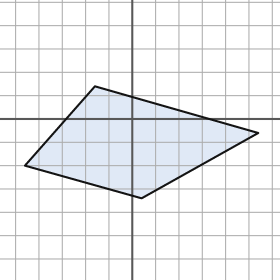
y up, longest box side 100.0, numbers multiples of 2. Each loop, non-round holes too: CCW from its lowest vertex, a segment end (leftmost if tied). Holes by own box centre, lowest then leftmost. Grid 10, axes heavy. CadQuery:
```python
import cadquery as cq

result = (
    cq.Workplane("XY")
    .moveTo(4.0, -34.0)
    .lineTo(54.0, -6.0)
    .lineTo(-16.0, 14.0)
    .lineTo(-46.0, -20.0)
    .close()
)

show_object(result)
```